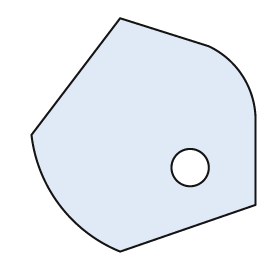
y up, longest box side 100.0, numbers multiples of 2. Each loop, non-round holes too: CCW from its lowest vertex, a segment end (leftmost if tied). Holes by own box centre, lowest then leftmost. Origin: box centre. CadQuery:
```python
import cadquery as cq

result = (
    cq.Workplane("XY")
    .moveTo(-10.0, -50.0)
    .lineTo(48.0, -30.0)
    .lineTo(48.0, 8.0)
    .threePointArc((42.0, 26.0), (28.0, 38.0))
    .lineTo(-10.0, 50.0)
    .lineTo(-48.0, 0.0)
    .threePointArc((-36.0, -30.0), (-10.0, -50.0))
    .close()
    .moveTo(20.0, -14.0)
    .circle(8.0)
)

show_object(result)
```